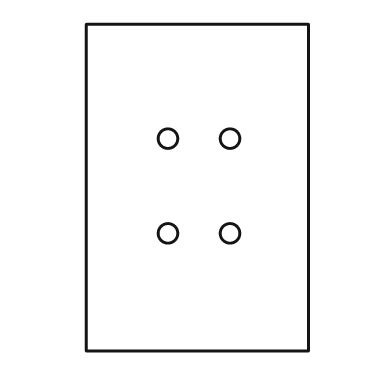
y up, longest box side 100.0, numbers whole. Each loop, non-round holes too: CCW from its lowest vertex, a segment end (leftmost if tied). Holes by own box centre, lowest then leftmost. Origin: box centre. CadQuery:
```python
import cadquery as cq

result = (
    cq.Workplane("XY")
    .moveTo(-34.0, -50.0)
    .lineTo(34.0, -50.0)
    .lineTo(34.0, 50.0)
    .lineTo(-34.0, 50.0)
    .close()
    .moveTo(-9.0, -14.0)
    .circle(3.0)
    .moveTo(10.0, -14.0)
    .circle(3.0)
    .moveTo(-9.0, 15.0)
    .circle(3.0)
    .moveTo(10.0, 15.0)
    .circle(3.0)
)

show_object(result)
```